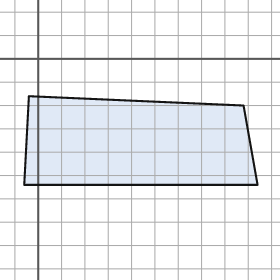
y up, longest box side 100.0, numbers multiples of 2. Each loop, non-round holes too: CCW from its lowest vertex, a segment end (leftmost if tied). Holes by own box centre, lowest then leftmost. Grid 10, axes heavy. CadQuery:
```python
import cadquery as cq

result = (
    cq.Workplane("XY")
    .moveTo(-6.0, -54.0)
    .lineTo(94.0, -54.0)
    .lineTo(88.0, -20.0)
    .lineTo(-4.0, -16.0)
    .close()
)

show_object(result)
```